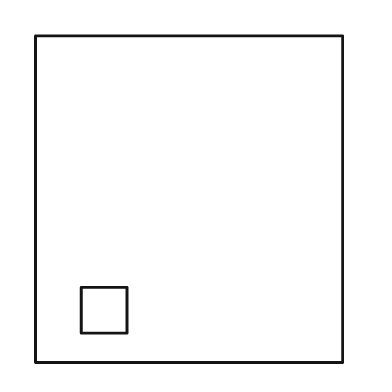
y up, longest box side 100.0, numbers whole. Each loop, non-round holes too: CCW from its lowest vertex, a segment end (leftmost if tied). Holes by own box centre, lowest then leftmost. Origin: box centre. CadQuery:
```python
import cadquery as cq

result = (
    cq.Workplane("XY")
    .moveTo(-47.0, -50.0)
    .lineTo(47.0, -50.0)
    .lineTo(47.0, 50.0)
    .lineTo(-47.0, 50.0)
    .close()
    .moveTo(-33.0, -41.0)
    .lineTo(-19.0, -41.0)
    .lineTo(-19.0, -27.0)
    .lineTo(-33.0, -27.0)
    .close()
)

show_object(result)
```